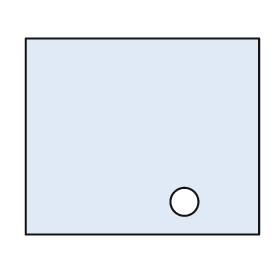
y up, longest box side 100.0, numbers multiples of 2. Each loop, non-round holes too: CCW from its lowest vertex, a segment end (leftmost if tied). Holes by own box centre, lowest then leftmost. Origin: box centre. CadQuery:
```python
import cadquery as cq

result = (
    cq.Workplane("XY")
    .moveTo(-50.0, -42.0)
    .lineTo(50.0, -42.0)
    .lineTo(50.0, 42.0)
    .lineTo(-50.0, 42.0)
    .close()
    .moveTo(18.0, -28.0)
    .circle(6.0)
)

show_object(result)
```